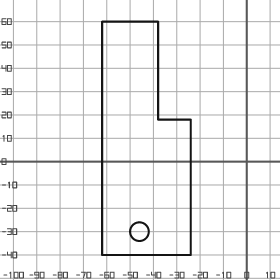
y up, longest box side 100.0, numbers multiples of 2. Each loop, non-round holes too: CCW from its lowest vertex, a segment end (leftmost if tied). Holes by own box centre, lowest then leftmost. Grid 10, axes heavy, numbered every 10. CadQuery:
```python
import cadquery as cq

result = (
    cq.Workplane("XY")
    .moveTo(-62.0, -40.0)
    .lineTo(-24.0, -40.0)
    .lineTo(-24.0, 18.0)
    .lineTo(-38.0, 18.0)
    .lineTo(-38.0, 60.0)
    .lineTo(-62.0, 60.0)
    .close()
    .moveTo(-46.0, -30.0)
    .circle(4.0)
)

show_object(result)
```